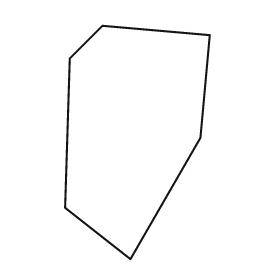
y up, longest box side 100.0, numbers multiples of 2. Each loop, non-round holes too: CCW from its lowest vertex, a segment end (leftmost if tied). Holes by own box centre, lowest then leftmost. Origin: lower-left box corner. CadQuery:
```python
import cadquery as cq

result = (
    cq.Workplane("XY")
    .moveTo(28.0, 0.0)
    .lineTo(58.0, 52.0)
    .lineTo(62.0, 96.0)
    .lineTo(16.0, 100.0)
    .lineTo(2.0, 86.0)
    .lineTo(0.0, 22.0)
    .close()
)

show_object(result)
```